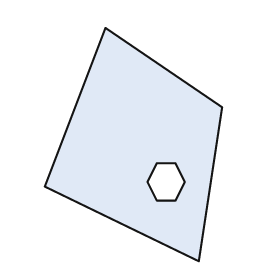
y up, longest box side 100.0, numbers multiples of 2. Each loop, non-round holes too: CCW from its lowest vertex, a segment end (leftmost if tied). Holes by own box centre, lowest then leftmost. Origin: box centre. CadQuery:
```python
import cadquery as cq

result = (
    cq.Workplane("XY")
    .moveTo(28.0, -50.0)
    .lineTo(38.0, 16.0)
    .lineTo(-12.0, 50.0)
    .lineTo(-38.0, -18.0)
    .close()
    .moveTo(10.0, -24.0)
    .lineTo(18.0, -24.0)
    .lineTo(22.0, -16.0)
    .lineTo(18.0, -8.0)
    .lineTo(10.0, -8.0)
    .lineTo(6.0, -16.0)
    .close()
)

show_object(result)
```